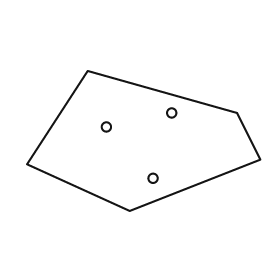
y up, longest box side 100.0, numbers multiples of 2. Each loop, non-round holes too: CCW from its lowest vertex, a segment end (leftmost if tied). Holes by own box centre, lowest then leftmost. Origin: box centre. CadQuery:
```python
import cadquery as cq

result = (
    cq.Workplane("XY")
    .moveTo(-6.0, -30.0)
    .lineTo(50.0, -8.0)
    .lineTo(40.0, 12.0)
    .lineTo(-24.0, 30.0)
    .lineTo(-50.0, -10.0)
    .close()
    .moveTo(4.0, -16.0)
    .circle(2.0)
    .moveTo(-16.0, 6.0)
    .circle(2.0)
    .moveTo(12.0, 12.0)
    .circle(2.0)
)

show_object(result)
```